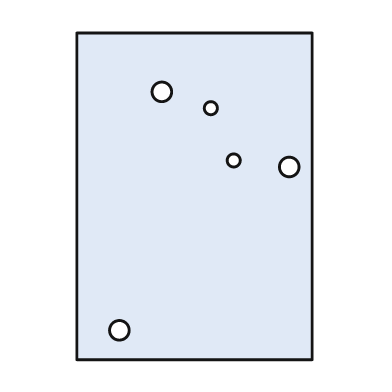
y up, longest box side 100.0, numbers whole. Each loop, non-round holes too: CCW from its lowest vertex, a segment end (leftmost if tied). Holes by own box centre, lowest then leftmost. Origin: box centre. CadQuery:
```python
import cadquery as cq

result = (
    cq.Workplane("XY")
    .moveTo(-36.0, -50.0)
    .lineTo(36.0, -50.0)
    .lineTo(36.0, 50.0)
    .lineTo(-36.0, 50.0)
    .close()
    .moveTo(-23.0, -41.0)
    .circle(3.0)
    .moveTo(29.0, 9.0)
    .circle(3.0)
    .moveTo(12.0, 11.0)
    .circle(2.0)
    .moveTo(5.0, 27.0)
    .circle(2.0)
    .moveTo(-10.0, 32.0)
    .circle(3.0)
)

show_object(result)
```